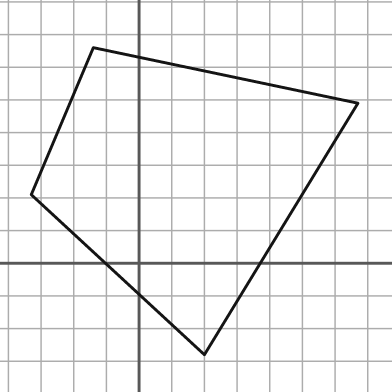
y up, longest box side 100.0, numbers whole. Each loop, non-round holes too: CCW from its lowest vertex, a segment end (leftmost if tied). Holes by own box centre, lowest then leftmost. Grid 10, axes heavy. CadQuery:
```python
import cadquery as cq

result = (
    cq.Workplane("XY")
    .moveTo(20.0, -28.0)
    .lineTo(67.0, 49.0)
    .lineTo(-14.0, 66.0)
    .lineTo(-33.0, 21.0)
    .close()
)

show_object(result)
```